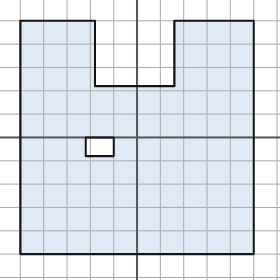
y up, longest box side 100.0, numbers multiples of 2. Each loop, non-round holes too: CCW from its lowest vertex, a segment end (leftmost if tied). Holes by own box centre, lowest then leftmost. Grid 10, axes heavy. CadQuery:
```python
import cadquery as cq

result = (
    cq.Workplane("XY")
    .moveTo(-50.0, -50.0)
    .lineTo(50.0, -50.0)
    .lineTo(50.0, 50.0)
    .lineTo(16.0, 50.0)
    .lineTo(16.0, 22.0)
    .lineTo(-18.0, 22.0)
    .lineTo(-18.0, 50.0)
    .lineTo(-50.0, 50.0)
    .close()
    .moveTo(-22.0, -8.0)
    .lineTo(-10.0, -8.0)
    .lineTo(-10.0, 0.0)
    .lineTo(-22.0, 0.0)
    .close()
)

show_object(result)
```